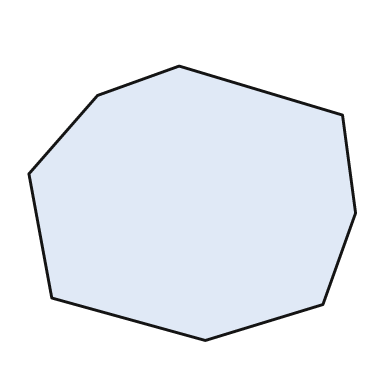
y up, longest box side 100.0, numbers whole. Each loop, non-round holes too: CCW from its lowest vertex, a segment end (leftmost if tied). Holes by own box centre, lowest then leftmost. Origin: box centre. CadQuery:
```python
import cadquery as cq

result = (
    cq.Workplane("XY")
    .moveTo(4.0, -42.0)
    .lineTo(40.0, -31.0)
    .lineTo(50.0, -3.0)
    .lineTo(46.0, 27.0)
    .lineTo(-4.0, 42.0)
    .lineTo(-29.0, 33.0)
    .lineTo(-50.0, 9.0)
    .lineTo(-43.0, -29.0)
    .close()
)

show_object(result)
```